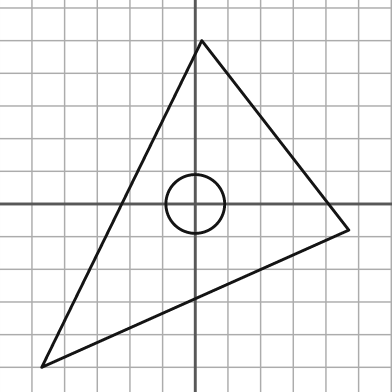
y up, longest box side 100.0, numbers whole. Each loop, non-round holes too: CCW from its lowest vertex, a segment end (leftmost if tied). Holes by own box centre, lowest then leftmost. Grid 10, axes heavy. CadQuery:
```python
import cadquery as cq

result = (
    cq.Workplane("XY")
    .moveTo(-47.0, -50.0)
    .lineTo(47.0, -8.0)
    .lineTo(2.0, 50.0)
    .close()
    .moveTo(0.0, 0.0)
    .circle(9.0)
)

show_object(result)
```